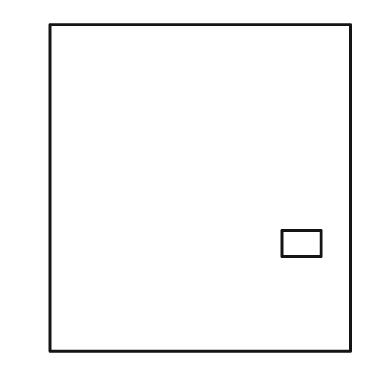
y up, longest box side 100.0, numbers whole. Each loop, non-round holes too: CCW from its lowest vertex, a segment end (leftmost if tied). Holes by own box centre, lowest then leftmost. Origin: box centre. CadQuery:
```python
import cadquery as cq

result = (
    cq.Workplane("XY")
    .moveTo(-46.0, -50.0)
    .lineTo(46.0, -50.0)
    .lineTo(46.0, 50.0)
    .lineTo(-46.0, 50.0)
    .close()
    .moveTo(25.0, -21.0)
    .lineTo(37.0, -21.0)
    .lineTo(37.0, -13.0)
    .lineTo(25.0, -13.0)
    .close()
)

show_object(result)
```